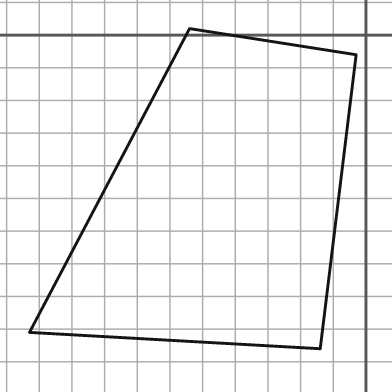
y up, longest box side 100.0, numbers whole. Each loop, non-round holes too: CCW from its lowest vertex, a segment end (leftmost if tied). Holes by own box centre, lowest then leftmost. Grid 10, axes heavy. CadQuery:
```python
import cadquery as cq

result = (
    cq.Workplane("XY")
    .moveTo(-14.0, -96.0)
    .lineTo(-3.0, -6.0)
    .lineTo(-54.0, 2.0)
    .lineTo(-103.0, -91.0)
    .close()
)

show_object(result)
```